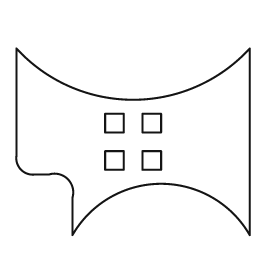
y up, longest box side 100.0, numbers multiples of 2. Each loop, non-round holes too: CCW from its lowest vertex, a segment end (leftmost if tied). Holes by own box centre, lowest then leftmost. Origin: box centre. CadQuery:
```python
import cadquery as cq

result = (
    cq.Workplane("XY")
    .moveTo(-26.0, -40.0)
    .threePointArc((12.0, -18.0), (50.0, -40.0))
    .lineTo(50.0, 40.0)
    .threePointArc((0.0, 18.0), (-50.0, 40.0))
    .lineTo(-50.0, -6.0)
    .threePointArc((-48.0, -12.0), (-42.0, -14.0))
    .lineTo(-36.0, -14.0)
    .threePointArc((-28.0, -16.0), (-26.0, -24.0))
    .close()
    .moveTo(-12.0, -12.0)
    .lineTo(-4.0, -12.0)
    .lineTo(-4.0, -4.0)
    .lineTo(-12.0, -4.0)
    .close()
    .moveTo(4.0, -12.0)
    .lineTo(12.0, -12.0)
    .lineTo(12.0, -4.0)
    .lineTo(4.0, -4.0)
    .close()
    .moveTo(-12.0, 4.0)
    .lineTo(-4.0, 4.0)
    .lineTo(-4.0, 12.0)
    .lineTo(-12.0, 12.0)
    .close()
    .moveTo(4.0, 4.0)
    .lineTo(12.0, 4.0)
    .lineTo(12.0, 12.0)
    .lineTo(4.0, 12.0)
    .close()
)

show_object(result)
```